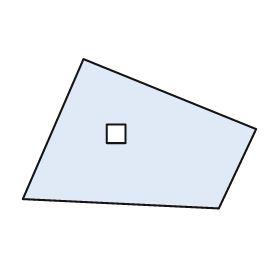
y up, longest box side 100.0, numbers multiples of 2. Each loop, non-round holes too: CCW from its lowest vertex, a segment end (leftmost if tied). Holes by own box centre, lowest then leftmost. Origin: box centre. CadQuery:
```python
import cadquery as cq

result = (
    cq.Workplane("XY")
    .moveTo(34.0, -32.0)
    .lineTo(50.0, 2.0)
    .lineTo(-24.0, 32.0)
    .lineTo(-50.0, -28.0)
    .close()
    .moveTo(-14.0, -4.0)
    .lineTo(-6.0, -4.0)
    .lineTo(-6.0, 4.0)
    .lineTo(-14.0, 4.0)
    .close()
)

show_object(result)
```